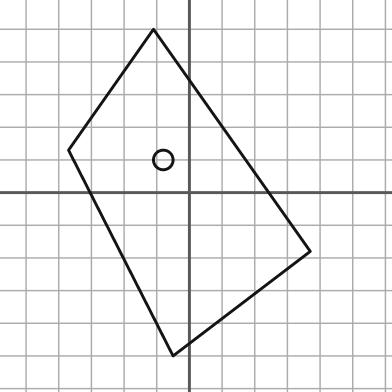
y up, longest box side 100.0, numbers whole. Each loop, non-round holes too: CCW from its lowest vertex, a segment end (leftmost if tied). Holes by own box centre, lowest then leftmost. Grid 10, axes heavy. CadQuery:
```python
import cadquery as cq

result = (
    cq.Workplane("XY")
    .moveTo(-5.0, -50.0)
    .lineTo(37.0, -18.0)
    .lineTo(-11.0, 50.0)
    .lineTo(-37.0, 13.0)
    .close()
    .moveTo(-8.0, 10.0)
    .circle(3.0)
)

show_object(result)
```